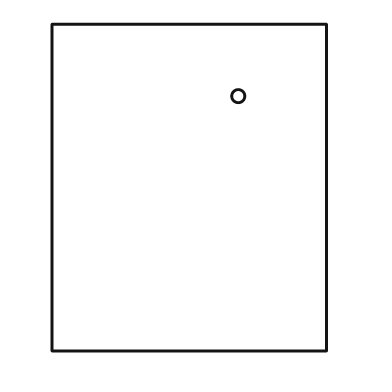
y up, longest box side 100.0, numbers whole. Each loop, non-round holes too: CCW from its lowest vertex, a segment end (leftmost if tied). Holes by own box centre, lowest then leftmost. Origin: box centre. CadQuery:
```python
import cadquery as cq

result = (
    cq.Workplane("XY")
    .moveTo(-42.0, -50.0)
    .lineTo(42.0, -50.0)
    .lineTo(42.0, 50.0)
    .lineTo(-42.0, 50.0)
    .close()
    .moveTo(15.0, 28.0)
    .circle(2.0)
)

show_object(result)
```